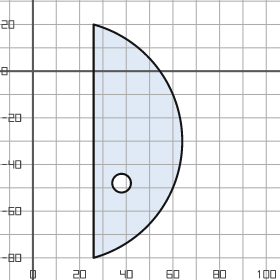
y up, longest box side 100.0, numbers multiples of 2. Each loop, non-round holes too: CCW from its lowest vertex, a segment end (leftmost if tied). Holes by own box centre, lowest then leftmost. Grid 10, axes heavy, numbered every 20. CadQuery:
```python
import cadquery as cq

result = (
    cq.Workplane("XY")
    .moveTo(26.0, -80.0)
    .threePointArc((64.0, -30.0), (26.0, 20.0))
    .close()
    .moveTo(38.0, -48.0)
    .circle(4.0)
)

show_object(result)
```